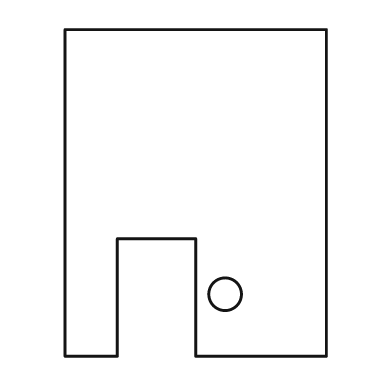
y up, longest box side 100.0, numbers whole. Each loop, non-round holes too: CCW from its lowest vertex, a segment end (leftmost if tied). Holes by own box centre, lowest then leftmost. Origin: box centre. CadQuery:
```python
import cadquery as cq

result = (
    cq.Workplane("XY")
    .moveTo(-40.0, -50.0)
    .lineTo(-24.0, -50.0)
    .lineTo(-24.0, -14.0)
    .lineTo(0.0, -14.0)
    .lineTo(0.0, -50.0)
    .lineTo(40.0, -50.0)
    .lineTo(40.0, 50.0)
    .lineTo(-40.0, 50.0)
    .close()
    .moveTo(9.0, -31.0)
    .circle(5.0)
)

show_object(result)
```